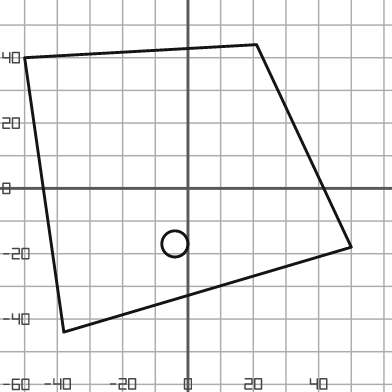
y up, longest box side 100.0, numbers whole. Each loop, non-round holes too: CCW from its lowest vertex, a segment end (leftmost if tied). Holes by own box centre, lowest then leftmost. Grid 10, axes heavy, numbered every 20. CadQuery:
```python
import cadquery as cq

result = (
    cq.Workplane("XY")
    .moveTo(-38.0, -44.0)
    .lineTo(50.0, -18.0)
    .lineTo(21.0, 44.0)
    .lineTo(-50.0, 40.0)
    .close()
    .moveTo(-4.0, -17.0)
    .circle(4.0)
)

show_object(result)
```